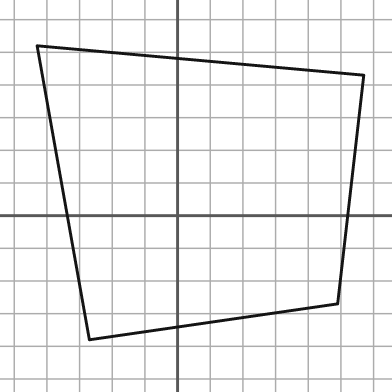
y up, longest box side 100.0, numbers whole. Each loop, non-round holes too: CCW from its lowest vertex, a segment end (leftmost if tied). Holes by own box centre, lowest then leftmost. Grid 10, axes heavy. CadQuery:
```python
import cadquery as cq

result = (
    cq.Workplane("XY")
    .moveTo(-27.0, -38.0)
    .lineTo(49.0, -27.0)
    .lineTo(57.0, 43.0)
    .lineTo(-43.0, 52.0)
    .close()
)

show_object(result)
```